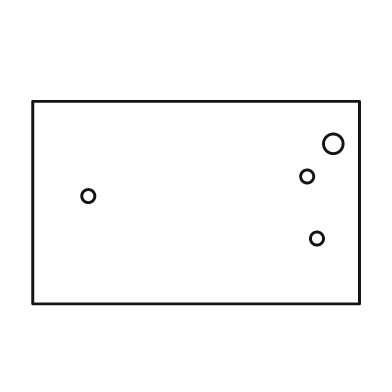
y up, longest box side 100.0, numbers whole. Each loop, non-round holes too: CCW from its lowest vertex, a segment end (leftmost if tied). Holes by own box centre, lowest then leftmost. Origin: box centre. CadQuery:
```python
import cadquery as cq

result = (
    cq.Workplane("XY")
    .moveTo(-50.0, -31.0)
    .lineTo(50.0, -31.0)
    .lineTo(50.0, 31.0)
    .lineTo(-50.0, 31.0)
    .close()
    .moveTo(37.0, -11.0)
    .circle(2.0)
    .moveTo(-33.0, 2.0)
    .circle(2.0)
    .moveTo(34.0, 8.0)
    .circle(2.0)
    .moveTo(42.0, 18.0)
    .circle(3.0)
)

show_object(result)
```